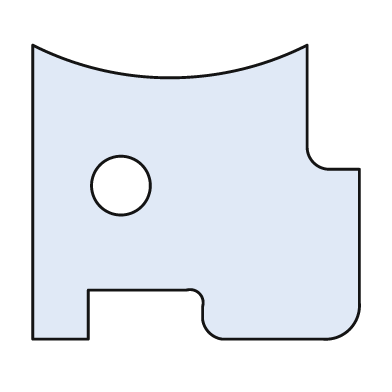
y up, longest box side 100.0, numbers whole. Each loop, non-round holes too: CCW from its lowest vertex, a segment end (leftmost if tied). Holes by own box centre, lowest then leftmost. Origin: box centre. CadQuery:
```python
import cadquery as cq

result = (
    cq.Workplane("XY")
    .moveTo(-50.0, -45.0)
    .lineTo(-33.0, -45.0)
    .lineTo(-33.0, -30.0)
    .lineTo(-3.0, -30.0)
    .threePointArc((1.0, -31.0), (2.0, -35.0))
    .lineTo(2.0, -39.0)
    .threePointArc((4.0, -43.0), (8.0, -45.0))
    .lineTo(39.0, -45.0)
    .threePointArc((47.0, -42.0), (50.0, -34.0))
    .lineTo(50.0, 7.0)
    .lineTo(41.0, 7.0)
    .threePointArc((36.0, 9.0), (34.0, 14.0))
    .lineTo(34.0, 45.0)
    .threePointArc((-8.0, 35.0), (-50.0, 45.0))
    .close()
    .moveTo(-23.0, 2.0)
    .circle(9.0)
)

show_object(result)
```